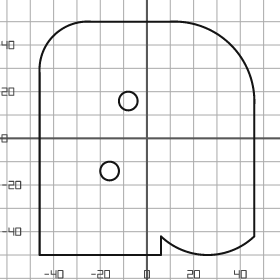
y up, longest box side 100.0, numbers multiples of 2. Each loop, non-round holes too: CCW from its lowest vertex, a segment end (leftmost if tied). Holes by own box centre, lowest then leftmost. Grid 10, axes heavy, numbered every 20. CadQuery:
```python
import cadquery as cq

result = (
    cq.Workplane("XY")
    .moveTo(-46.0, -50.0)
    .lineTo(6.0, -50.0)
    .lineTo(6.0, -42.0)
    .threePointArc((26.0, -50.0), (46.0, -42.0))
    .lineTo(46.0, 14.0)
    .threePointArc((36.0, 40.0), (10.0, 50.0))
    .lineTo(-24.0, 50.0)
    .threePointArc((-40.0, 44.0), (-46.0, 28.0))
    .close()
    .moveTo(-16.0, -14.0)
    .circle(4.0)
    .moveTo(-8.0, 16.0)
    .circle(4.0)
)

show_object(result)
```